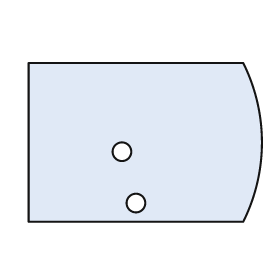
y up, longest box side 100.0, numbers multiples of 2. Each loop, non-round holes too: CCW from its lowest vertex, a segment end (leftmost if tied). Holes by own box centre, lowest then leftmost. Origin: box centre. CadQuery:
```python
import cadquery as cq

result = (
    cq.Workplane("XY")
    .moveTo(-50.0, -34.0)
    .lineTo(42.0, -34.0)
    .threePointArc((50.0, 0.0), (42.0, 34.0))
    .lineTo(-50.0, 34.0)
    .close()
    .moveTo(-4.0, -26.0)
    .circle(4.0)
    .moveTo(-10.0, -4.0)
    .circle(4.0)
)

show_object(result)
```